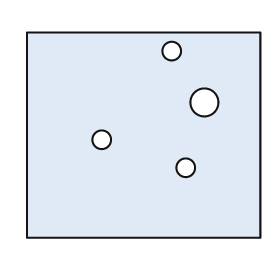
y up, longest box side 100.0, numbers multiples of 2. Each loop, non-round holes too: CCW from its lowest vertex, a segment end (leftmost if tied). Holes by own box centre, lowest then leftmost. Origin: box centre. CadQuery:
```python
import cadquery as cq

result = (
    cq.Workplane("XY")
    .moveTo(-50.0, -44.0)
    .lineTo(50.0, -44.0)
    .lineTo(50.0, 44.0)
    .lineTo(-50.0, 44.0)
    .close()
    .moveTo(18.0, -14.0)
    .circle(4.0)
    .moveTo(-18.0, -2.0)
    .circle(4.0)
    .moveTo(26.0, 14.0)
    .circle(6.0)
    .moveTo(12.0, 36.0)
    .circle(4.0)
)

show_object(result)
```